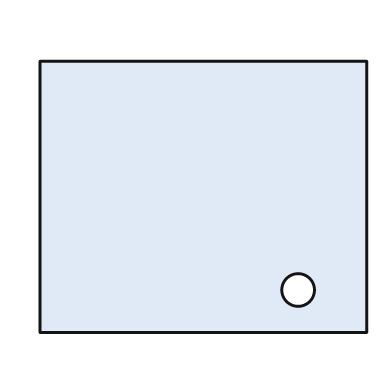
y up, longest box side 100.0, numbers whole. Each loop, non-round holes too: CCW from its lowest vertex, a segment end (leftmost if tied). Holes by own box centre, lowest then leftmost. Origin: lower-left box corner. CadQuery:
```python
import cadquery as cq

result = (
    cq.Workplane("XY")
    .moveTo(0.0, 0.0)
    .lineTo(100.0, 0.0)
    .lineTo(100.0, 83.0)
    .lineTo(0.0, 83.0)
    .close()
    .moveTo(79.0, 13.0)
    .circle(5.0)
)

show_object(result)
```